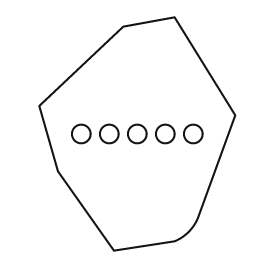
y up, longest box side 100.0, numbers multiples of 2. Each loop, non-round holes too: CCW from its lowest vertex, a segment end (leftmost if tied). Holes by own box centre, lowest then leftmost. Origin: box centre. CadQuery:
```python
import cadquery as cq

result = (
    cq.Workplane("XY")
    .moveTo(-10.0, -50.0)
    .lineTo(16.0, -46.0)
    .threePointArc((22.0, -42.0), (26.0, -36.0))
    .lineTo(42.0, 8.0)
    .lineTo(16.0, 50.0)
    .lineTo(-6.0, 46.0)
    .lineTo(-42.0, 12.0)
    .lineTo(-34.0, -16.0)
    .close()
    .moveTo(-24.0, 0.0)
    .circle(4.0)
    .moveTo(-12.0, 0.0)
    .circle(4.0)
    .moveTo(0.0, 0.0)
    .circle(4.0)
    .moveTo(12.0, 0.0)
    .circle(4.0)
    .moveTo(24.0, 0.0)
    .circle(4.0)
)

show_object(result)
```